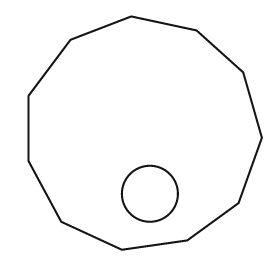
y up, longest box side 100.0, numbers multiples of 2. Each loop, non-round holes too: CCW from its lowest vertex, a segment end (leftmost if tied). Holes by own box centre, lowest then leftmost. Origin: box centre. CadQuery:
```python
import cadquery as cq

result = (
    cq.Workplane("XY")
    .moveTo(-10.0, -50.0)
    .lineTo(18.0, -46.0)
    .lineTo(40.0, -30.0)
    .lineTo(50.0, -2.0)
    .lineTo(42.0, 26.0)
    .lineTo(22.0, 44.0)
    .lineTo(-6.0, 50.0)
    .lineTo(-32.0, 40.0)
    .lineTo(-50.0, 16.0)
    .lineTo(-50.0, -12.0)
    .lineTo(-36.0, -38.0)
    .close()
    .moveTo(2.0, -26.0)
    .circle(12.0)
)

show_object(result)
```